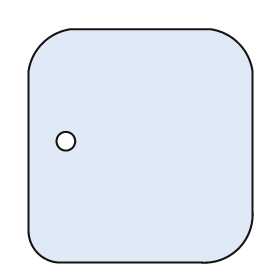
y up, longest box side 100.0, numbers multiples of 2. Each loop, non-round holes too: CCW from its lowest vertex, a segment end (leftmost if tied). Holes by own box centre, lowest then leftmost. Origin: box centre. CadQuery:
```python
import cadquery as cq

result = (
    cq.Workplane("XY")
    .moveTo(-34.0, -50.0)
    .lineTo(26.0, -50.0)
    .threePointArc((42.0, -44.0), (48.0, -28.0))
    .lineTo(48.0, 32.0)
    .threePointArc((42.0, 44.0), (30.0, 50.0))
    .lineTo(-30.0, 50.0)
    .threePointArc((-42.0, 44.0), (-48.0, 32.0))
    .lineTo(-48.0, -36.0)
    .threePointArc((-44.0, -46.0), (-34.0, -50.0))
    .close()
    .moveTo(-32.0, 2.0)
    .circle(4.0)
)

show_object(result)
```